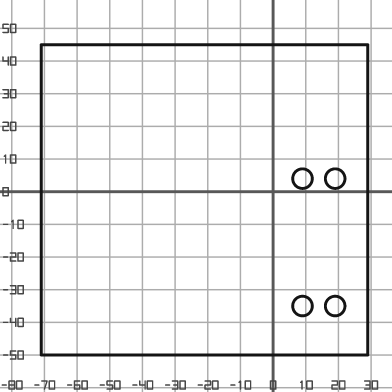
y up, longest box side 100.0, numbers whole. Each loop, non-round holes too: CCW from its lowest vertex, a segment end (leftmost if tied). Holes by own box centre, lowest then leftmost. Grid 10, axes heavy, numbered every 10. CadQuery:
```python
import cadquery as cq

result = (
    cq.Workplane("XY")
    .moveTo(-71.0, -50.0)
    .lineTo(29.0, -50.0)
    .lineTo(29.0, 45.0)
    .lineTo(-71.0, 45.0)
    .close()
    .moveTo(9.0, -35.0)
    .circle(3.0)
    .moveTo(19.0, -35.0)
    .circle(3.0)
    .moveTo(9.0, 4.0)
    .circle(3.0)
    .moveTo(19.0, 4.0)
    .circle(3.0)
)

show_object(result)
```